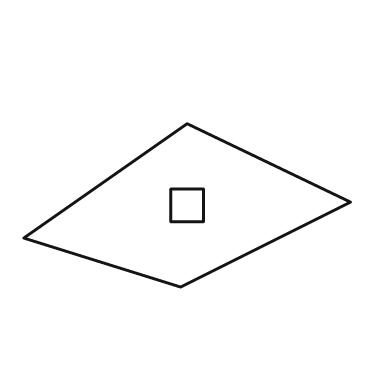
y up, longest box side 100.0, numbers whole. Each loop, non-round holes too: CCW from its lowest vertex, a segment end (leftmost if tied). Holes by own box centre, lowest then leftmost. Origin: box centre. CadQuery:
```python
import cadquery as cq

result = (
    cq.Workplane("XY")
    .moveTo(-2.0, -25.0)
    .lineTo(50.0, 1.0)
    .lineTo(0.0, 25.0)
    .lineTo(-50.0, -10.0)
    .close()
    .moveTo(-5.0, -5.0)
    .lineTo(5.0, -5.0)
    .lineTo(5.0, 5.0)
    .lineTo(-5.0, 5.0)
    .close()
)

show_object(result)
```